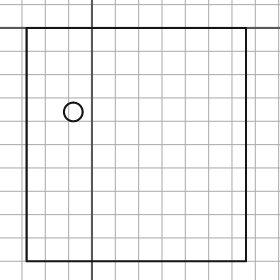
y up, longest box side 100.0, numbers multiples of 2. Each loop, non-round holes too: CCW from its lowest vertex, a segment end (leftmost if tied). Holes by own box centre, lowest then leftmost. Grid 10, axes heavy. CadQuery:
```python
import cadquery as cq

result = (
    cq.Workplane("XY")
    .moveTo(-28.0, -100.0)
    .lineTo(66.0, -100.0)
    .lineTo(66.0, 0.0)
    .lineTo(-28.0, 0.0)
    .close()
    .moveTo(-8.0, -36.0)
    .circle(4.0)
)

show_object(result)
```